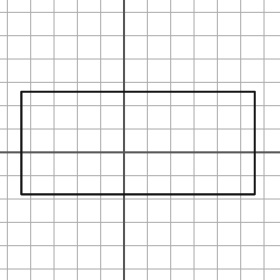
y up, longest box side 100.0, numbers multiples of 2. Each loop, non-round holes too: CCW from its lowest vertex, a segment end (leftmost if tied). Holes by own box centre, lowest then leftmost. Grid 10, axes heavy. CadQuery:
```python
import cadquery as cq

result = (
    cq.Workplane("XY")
    .moveTo(-44.0, -18.0)
    .lineTo(56.0, -18.0)
    .lineTo(56.0, 26.0)
    .lineTo(-44.0, 26.0)
    .close()
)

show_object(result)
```